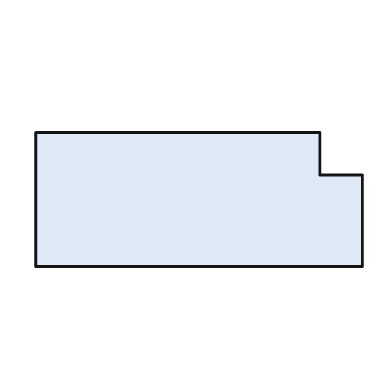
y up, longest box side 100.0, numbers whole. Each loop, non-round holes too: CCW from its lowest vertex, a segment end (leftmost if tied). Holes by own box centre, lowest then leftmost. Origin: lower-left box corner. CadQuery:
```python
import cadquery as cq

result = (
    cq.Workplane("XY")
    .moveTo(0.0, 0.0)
    .lineTo(100.0, 0.0)
    .lineTo(100.0, 28.0)
    .lineTo(87.0, 28.0)
    .lineTo(87.0, 41.0)
    .lineTo(0.0, 41.0)
    .close()
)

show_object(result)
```